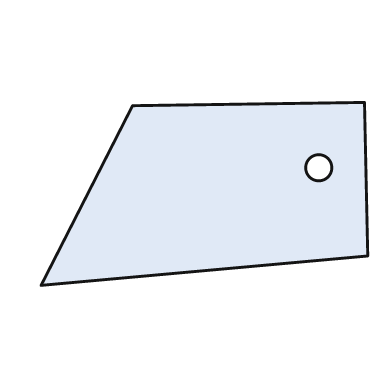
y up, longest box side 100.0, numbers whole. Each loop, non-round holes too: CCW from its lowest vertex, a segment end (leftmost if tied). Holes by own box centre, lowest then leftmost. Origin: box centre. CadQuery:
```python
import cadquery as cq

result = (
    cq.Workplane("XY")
    .moveTo(-50.0, -28.0)
    .lineTo(50.0, -19.0)
    .lineTo(49.0, 28.0)
    .lineTo(-22.0, 27.0)
    .close()
    .moveTo(35.0, 8.0)
    .circle(4.0)
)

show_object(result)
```